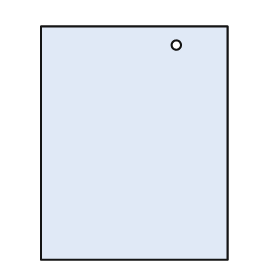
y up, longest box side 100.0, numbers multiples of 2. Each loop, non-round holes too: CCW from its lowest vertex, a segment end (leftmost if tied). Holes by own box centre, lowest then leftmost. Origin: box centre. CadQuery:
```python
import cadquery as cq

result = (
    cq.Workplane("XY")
    .moveTo(-40.0, -50.0)
    .lineTo(40.0, -50.0)
    .lineTo(40.0, 50.0)
    .lineTo(-40.0, 50.0)
    .close()
    .moveTo(18.0, 42.0)
    .circle(2.0)
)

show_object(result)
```